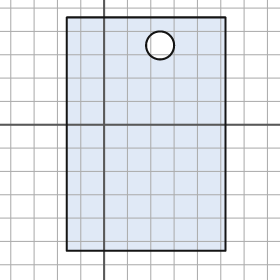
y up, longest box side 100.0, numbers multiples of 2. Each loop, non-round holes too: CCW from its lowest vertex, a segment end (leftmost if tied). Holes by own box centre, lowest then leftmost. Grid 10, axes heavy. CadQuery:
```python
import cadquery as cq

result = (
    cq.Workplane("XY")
    .moveTo(-16.0, -54.0)
    .lineTo(52.0, -54.0)
    .lineTo(52.0, 46.0)
    .lineTo(-16.0, 46.0)
    .close()
    .moveTo(24.0, 34.0)
    .circle(6.0)
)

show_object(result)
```